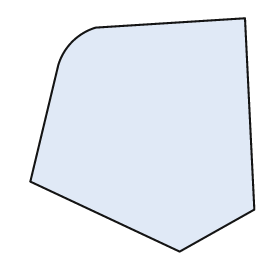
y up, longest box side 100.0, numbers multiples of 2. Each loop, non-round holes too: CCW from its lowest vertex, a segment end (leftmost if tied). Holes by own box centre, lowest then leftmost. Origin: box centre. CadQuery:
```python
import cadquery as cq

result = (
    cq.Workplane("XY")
    .moveTo(16.0, -50.0)
    .lineTo(48.0, -32.0)
    .lineTo(44.0, 50.0)
    .lineTo(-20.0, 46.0)
    .threePointArc((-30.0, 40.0), (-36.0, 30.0))
    .lineTo(-48.0, -20.0)
    .close()
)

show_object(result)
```